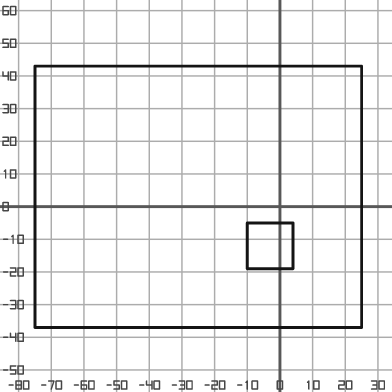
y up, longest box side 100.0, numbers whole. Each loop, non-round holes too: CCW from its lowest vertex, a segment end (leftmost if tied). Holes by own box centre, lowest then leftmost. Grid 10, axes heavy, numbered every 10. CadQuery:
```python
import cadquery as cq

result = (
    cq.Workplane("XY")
    .moveTo(-75.0, -37.0)
    .lineTo(25.0, -37.0)
    .lineTo(25.0, 43.0)
    .lineTo(-75.0, 43.0)
    .close()
    .moveTo(-10.0, -19.0)
    .lineTo(4.0, -19.0)
    .lineTo(4.0, -5.0)
    .lineTo(-10.0, -5.0)
    .close()
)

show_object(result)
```